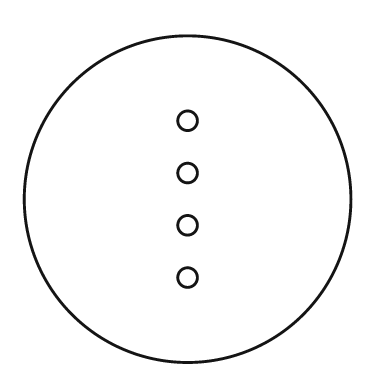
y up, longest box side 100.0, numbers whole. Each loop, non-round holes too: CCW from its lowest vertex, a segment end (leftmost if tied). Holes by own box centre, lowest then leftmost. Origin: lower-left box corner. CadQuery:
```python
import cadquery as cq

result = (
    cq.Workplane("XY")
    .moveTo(50.0, 50.0)
    .circle(50.0)
    .moveTo(50.0, 26.0)
    .circle(3.0)
    .moveTo(50.0, 42.0)
    .circle(3.0)
    .moveTo(50.0, 58.0)
    .circle(3.0)
    .moveTo(50.0, 74.0)
    .circle(3.0)
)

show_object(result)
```